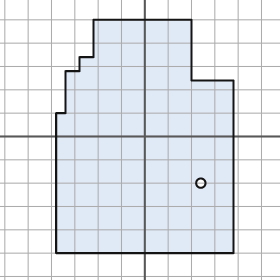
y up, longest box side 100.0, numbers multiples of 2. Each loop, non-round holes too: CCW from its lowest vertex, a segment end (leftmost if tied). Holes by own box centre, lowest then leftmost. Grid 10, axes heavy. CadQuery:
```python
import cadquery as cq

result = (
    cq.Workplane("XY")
    .moveTo(-38.0, -50.0)
    .lineTo(38.0, -50.0)
    .lineTo(38.0, 24.0)
    .lineTo(20.0, 24.0)
    .lineTo(20.0, 50.0)
    .lineTo(-22.0, 50.0)
    .lineTo(-22.0, 34.0)
    .lineTo(-28.0, 34.0)
    .lineTo(-28.0, 28.0)
    .lineTo(-34.0, 28.0)
    .lineTo(-34.0, 10.0)
    .lineTo(-38.0, 10.0)
    .close()
    .moveTo(24.0, -20.0)
    .circle(2.0)
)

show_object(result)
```